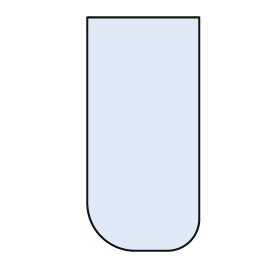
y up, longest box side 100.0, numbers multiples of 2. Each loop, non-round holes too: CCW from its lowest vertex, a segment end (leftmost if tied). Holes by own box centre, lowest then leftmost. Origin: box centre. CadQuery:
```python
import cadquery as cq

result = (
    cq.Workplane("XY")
    .moveTo(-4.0, -50.0)
    .lineTo(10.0, -50.0)
    .threePointArc((20.0, -46.0), (24.0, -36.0))
    .lineTo(24.0, 50.0)
    .lineTo(-24.0, 50.0)
    .lineTo(-24.0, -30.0)
    .threePointArc((-18.0, -44.0), (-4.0, -50.0))
    .close()
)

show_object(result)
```